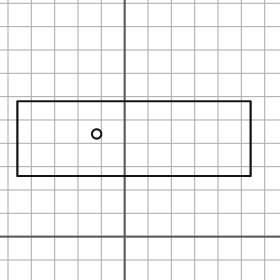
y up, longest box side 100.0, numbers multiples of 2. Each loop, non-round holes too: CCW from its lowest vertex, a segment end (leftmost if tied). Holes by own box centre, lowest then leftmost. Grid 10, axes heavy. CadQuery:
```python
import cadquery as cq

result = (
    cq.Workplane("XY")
    .moveTo(-46.0, 26.0)
    .lineTo(54.0, 26.0)
    .lineTo(54.0, 58.0)
    .lineTo(-46.0, 58.0)
    .close()
    .moveTo(-12.0, 44.0)
    .circle(2.0)
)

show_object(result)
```